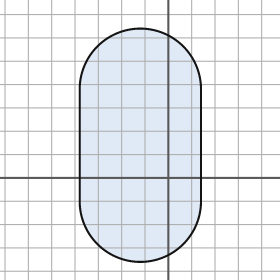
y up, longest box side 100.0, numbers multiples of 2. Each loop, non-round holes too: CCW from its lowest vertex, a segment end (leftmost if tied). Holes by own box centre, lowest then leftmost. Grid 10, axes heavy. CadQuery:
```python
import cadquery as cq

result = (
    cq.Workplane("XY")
    .moveTo(-38.0, -10.0)
    .threePointArc((-12.0, -36.0), (14.0, -10.0))
    .lineTo(14.0, 38.0)
    .threePointArc((-12.0, 64.0), (-38.0, 38.0))
    .close()
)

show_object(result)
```